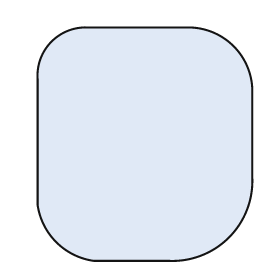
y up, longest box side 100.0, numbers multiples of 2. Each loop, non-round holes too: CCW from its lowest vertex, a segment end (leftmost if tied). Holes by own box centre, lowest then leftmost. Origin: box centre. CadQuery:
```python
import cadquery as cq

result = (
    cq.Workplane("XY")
    .moveTo(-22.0, -50.0)
    .lineTo(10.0, -50.0)
    .threePointArc((36.0, -40.0), (46.0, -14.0))
    .lineTo(46.0, 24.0)
    .threePointArc((38.0, 42.0), (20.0, 50.0))
    .lineTo(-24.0, 50.0)
    .threePointArc((-40.0, 44.0), (-46.0, 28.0))
    .lineTo(-46.0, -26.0)
    .threePointArc((-38.0, -42.0), (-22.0, -50.0))
    .close()
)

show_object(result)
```